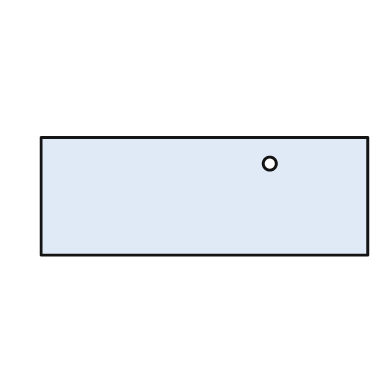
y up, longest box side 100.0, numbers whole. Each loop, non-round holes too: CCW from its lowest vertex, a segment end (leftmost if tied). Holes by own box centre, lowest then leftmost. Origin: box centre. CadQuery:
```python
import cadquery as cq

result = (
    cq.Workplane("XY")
    .moveTo(-50.0, -18.0)
    .lineTo(50.0, -18.0)
    .lineTo(50.0, 18.0)
    .lineTo(-50.0, 18.0)
    .close()
    .moveTo(20.0, 10.0)
    .circle(2.0)
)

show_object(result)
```